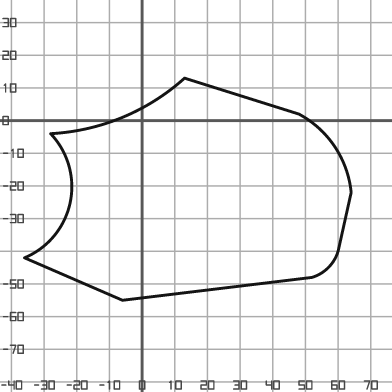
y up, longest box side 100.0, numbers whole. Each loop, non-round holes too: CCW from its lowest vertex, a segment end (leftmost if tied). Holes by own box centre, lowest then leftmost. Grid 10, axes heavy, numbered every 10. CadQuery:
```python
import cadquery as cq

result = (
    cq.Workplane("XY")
    .moveTo(-6.0, -55.0)
    .lineTo(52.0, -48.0)
    .threePointArc((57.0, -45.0), (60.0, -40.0))
    .lineTo(64.0, -22.0)
    .threePointArc((59.0, -8.0), (48.0, 2.0))
    .lineTo(13.0, 13.0)
    .threePointArc((-6.0, 1.0), (-28.0, -4.0))
    .threePointArc((-22.0, -25.0), (-36.0, -42.0))
    .close()
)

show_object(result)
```